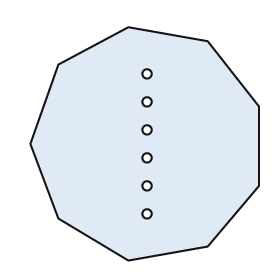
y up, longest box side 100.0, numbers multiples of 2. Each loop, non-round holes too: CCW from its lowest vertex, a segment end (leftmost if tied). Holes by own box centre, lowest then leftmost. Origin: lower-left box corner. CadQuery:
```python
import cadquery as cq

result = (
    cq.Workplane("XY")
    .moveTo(42.0, 0.0)
    .lineTo(76.0, 6.0)
    .lineTo(98.0, 32.0)
    .lineTo(98.0, 66.0)
    .lineTo(76.0, 94.0)
    .lineTo(42.0, 100.0)
    .lineTo(12.0, 84.0)
    .lineTo(0.0, 50.0)
    .lineTo(12.0, 18.0)
    .close()
    .moveTo(50.0, 20.0)
    .circle(2.0)
    .moveTo(50.0, 32.0)
    .circle(2.0)
    .moveTo(50.0, 44.0)
    .circle(2.0)
    .moveTo(50.0, 56.0)
    .circle(2.0)
    .moveTo(50.0, 68.0)
    .circle(2.0)
    .moveTo(50.0, 80.0)
    .circle(2.0)
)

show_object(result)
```